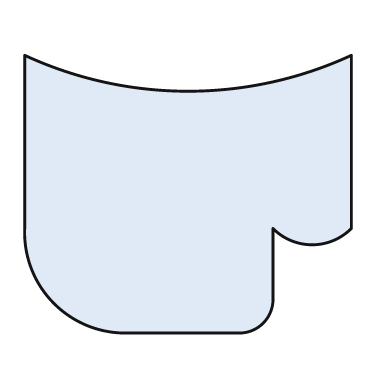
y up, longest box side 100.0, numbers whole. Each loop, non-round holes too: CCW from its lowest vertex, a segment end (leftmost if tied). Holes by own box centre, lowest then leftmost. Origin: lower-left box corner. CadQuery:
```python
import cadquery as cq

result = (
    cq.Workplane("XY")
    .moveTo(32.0, 0.0)
    .lineTo(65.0, 0.0)
    .threePointArc((73.0, 3.0), (76.0, 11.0))
    .lineTo(76.0, 32.0)
    .threePointArc((88.0, 27.0), (100.0, 32.0))
    .lineTo(100.0, 85.0)
    .threePointArc((50.0, 74.0), (0.0, 85.0))
    .lineTo(0.0, 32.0)
    .threePointArc((9.0, 9.0), (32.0, 0.0))
    .close()
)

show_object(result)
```